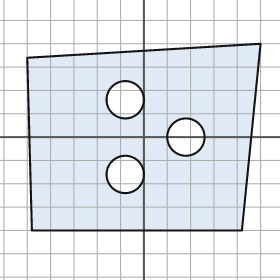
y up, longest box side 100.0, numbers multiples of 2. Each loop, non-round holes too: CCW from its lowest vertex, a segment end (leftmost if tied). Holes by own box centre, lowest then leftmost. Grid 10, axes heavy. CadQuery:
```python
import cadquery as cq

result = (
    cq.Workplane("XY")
    .moveTo(-48.0, -40.0)
    .lineTo(42.0, -40.0)
    .lineTo(50.0, 40.0)
    .lineTo(-50.0, 34.0)
    .close()
    .moveTo(-8.0, -16.0)
    .circle(8.0)
    .moveTo(18.0, 0.0)
    .circle(8.0)
    .moveTo(-8.0, 16.0)
    .circle(8.0)
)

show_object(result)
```